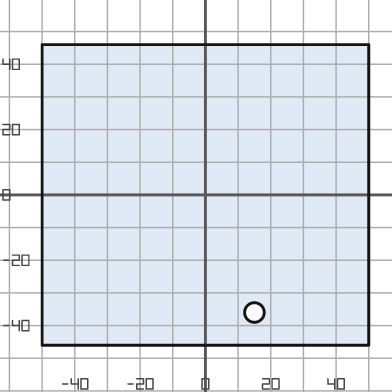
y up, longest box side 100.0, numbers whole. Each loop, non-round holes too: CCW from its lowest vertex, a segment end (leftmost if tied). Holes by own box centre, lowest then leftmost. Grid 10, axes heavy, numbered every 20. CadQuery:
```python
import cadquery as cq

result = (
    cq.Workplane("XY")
    .moveTo(-50.0, -46.0)
    .lineTo(50.0, -46.0)
    .lineTo(50.0, 46.0)
    .lineTo(-50.0, 46.0)
    .close()
    .moveTo(15.0, -36.0)
    .circle(3.0)
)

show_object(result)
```